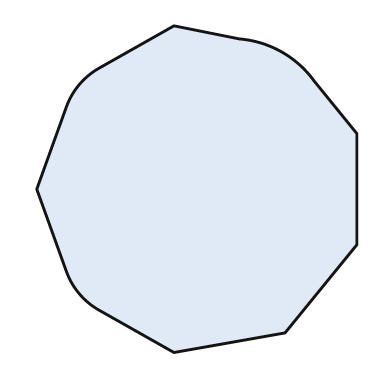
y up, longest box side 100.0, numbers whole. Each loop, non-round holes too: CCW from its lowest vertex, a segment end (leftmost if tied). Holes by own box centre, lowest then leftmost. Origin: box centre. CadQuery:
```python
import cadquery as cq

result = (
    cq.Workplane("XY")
    .moveTo(-7.0, -50.0)
    .lineTo(27.0, -44.0)
    .lineTo(49.0, -17.0)
    .lineTo(49.0, 17.0)
    .lineTo(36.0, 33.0)
    .threePointArc((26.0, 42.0), (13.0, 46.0))
    .lineTo(-7.0, 50.0)
    .lineTo(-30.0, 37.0)
    .threePointArc((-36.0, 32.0), (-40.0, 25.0))
    .lineTo(-49.0, 0.0)
    .lineTo(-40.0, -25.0)
    .threePointArc((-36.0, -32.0), (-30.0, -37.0))
    .close()
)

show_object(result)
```